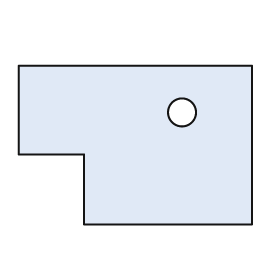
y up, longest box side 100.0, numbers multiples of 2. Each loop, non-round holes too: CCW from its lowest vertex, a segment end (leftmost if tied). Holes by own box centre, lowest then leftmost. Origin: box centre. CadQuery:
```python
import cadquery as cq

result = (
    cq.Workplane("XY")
    .moveTo(-22.0, -34.0)
    .lineTo(50.0, -34.0)
    .lineTo(50.0, 34.0)
    .lineTo(-50.0, 34.0)
    .lineTo(-50.0, -4.0)
    .lineTo(-22.0, -4.0)
    .close()
    .moveTo(20.0, 14.0)
    .circle(6.0)
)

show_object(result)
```